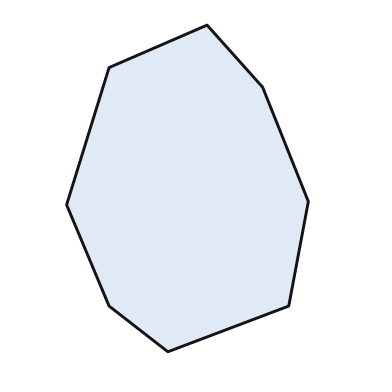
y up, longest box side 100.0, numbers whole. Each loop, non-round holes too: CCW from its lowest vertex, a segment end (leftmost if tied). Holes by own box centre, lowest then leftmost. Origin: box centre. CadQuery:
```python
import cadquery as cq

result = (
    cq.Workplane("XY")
    .moveTo(-6.0, -50.0)
    .lineTo(31.0, -36.0)
    .lineTo(37.0, -4.0)
    .lineTo(23.0, 31.0)
    .lineTo(6.0, 50.0)
    .lineTo(-24.0, 37.0)
    .lineTo(-37.0, -5.0)
    .lineTo(-24.0, -36.0)
    .close()
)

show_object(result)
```